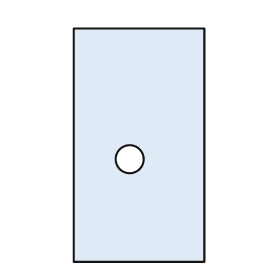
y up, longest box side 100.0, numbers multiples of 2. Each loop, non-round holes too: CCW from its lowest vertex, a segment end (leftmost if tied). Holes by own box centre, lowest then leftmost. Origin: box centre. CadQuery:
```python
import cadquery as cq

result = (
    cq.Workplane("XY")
    .moveTo(-28.0, -50.0)
    .lineTo(28.0, -50.0)
    .lineTo(28.0, 50.0)
    .lineTo(-28.0, 50.0)
    .close()
    .moveTo(-4.0, -6.0)
    .circle(6.0)
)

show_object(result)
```